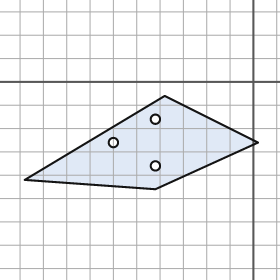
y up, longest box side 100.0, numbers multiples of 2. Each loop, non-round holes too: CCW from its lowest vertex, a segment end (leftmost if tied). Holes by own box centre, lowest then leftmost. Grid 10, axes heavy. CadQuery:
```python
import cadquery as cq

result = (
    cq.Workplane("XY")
    .moveTo(-42.0, -46.0)
    .lineTo(2.0, -26.0)
    .lineTo(-38.0, -6.0)
    .lineTo(-98.0, -42.0)
    .close()
    .moveTo(-42.0, -36.0)
    .circle(2.0)
    .moveTo(-60.0, -26.0)
    .circle(2.0)
    .moveTo(-42.0, -16.0)
    .circle(2.0)
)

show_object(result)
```